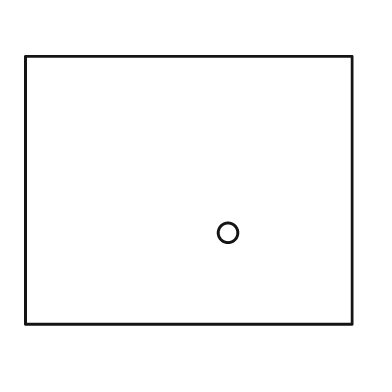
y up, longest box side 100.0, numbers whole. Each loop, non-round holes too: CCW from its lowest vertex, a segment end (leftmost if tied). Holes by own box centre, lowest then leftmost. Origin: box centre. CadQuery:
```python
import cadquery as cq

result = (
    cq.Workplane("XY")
    .moveTo(-50.0, -41.0)
    .lineTo(50.0, -41.0)
    .lineTo(50.0, 41.0)
    .lineTo(-50.0, 41.0)
    .close()
    .moveTo(12.0, -13.0)
    .circle(3.0)
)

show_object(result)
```